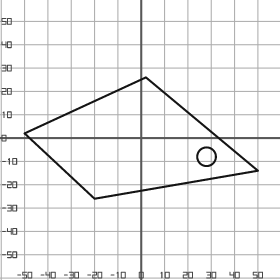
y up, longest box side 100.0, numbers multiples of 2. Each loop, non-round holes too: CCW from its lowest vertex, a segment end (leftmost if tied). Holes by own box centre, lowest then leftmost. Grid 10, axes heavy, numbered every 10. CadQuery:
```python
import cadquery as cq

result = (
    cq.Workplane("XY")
    .moveTo(-20.0, -26.0)
    .lineTo(50.0, -14.0)
    .lineTo(2.0, 26.0)
    .lineTo(-50.0, 2.0)
    .close()
    .moveTo(28.0, -8.0)
    .circle(4.0)
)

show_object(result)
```